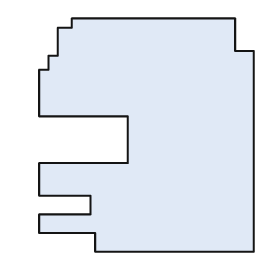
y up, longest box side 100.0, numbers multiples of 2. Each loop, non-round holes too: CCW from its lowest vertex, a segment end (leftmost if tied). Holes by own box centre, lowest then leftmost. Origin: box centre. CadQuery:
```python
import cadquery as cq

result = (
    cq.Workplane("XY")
    .moveTo(-22.0, -50.0)
    .lineTo(46.0, -50.0)
    .lineTo(46.0, 36.0)
    .lineTo(38.0, 36.0)
    .lineTo(38.0, 50.0)
    .lineTo(-32.0, 50.0)
    .lineTo(-32.0, 46.0)
    .lineTo(-38.0, 46.0)
    .lineTo(-38.0, 34.0)
    .lineTo(-42.0, 34.0)
    .lineTo(-42.0, 28.0)
    .lineTo(-46.0, 28.0)
    .lineTo(-46.0, 8.0)
    .lineTo(-8.0, 8.0)
    .lineTo(-8.0, -12.0)
    .lineTo(-46.0, -12.0)
    .lineTo(-46.0, -26.0)
    .lineTo(-24.0, -26.0)
    .lineTo(-24.0, -34.0)
    .lineTo(-46.0, -34.0)
    .lineTo(-46.0, -42.0)
    .lineTo(-22.0, -42.0)
    .close()
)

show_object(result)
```